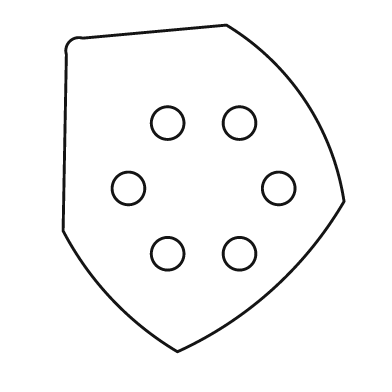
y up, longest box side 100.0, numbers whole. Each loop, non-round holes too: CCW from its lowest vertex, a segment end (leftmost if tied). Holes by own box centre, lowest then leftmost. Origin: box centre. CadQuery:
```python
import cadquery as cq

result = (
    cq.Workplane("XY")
    .moveTo(-8.0, -50.0)
    .threePointArc((21.0, -31.0), (43.0, -4.0))
    .threePointArc((31.0, 27.0), (7.0, 50.0))
    .lineTo(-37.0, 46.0)
    .threePointArc((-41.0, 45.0), (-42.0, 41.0))
    .lineTo(-43.0, -13.0)
    .threePointArc((-28.0, -34.0), (-8.0, -50.0))
    .close()
    .moveTo(-11.0, -20.0)
    .circle(5.0)
    .moveTo(11.0, -20.0)
    .circle(5.0)
    .moveTo(-23.0, 0.0)
    .circle(5.0)
    .moveTo(23.0, 0.0)
    .circle(5.0)
    .moveTo(-11.0, 20.0)
    .circle(5.0)
    .moveTo(11.0, 20.0)
    .circle(5.0)
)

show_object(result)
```